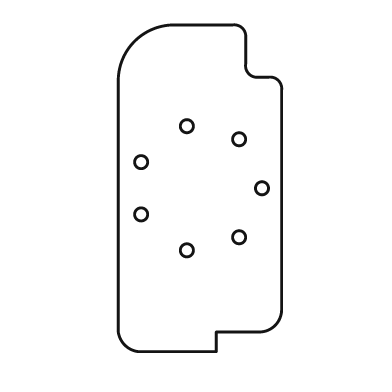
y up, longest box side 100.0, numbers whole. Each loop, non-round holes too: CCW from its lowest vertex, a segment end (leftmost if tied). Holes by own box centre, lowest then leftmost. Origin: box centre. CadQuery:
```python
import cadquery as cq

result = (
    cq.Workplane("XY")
    .moveTo(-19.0, -50.0)
    .lineTo(5.0, -50.0)
    .lineTo(5.0, -44.0)
    .lineTo(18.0, -44.0)
    .threePointArc((23.0, -42.0), (25.0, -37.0))
    .lineTo(25.0, 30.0)
    .threePointArc((24.0, 33.0), (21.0, 34.0))
    .lineTo(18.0, 34.0)
    .threePointArc((15.0, 35.0), (14.0, 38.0))
    .lineTo(14.0, 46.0)
    .threePointArc((13.0, 49.0), (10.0, 50.0))
    .lineTo(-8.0, 50.0)
    .threePointArc((-20.0, 45.0), (-25.0, 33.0))
    .lineTo(-25.0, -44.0)
    .threePointArc((-23.0, -48.0), (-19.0, -50.0))
    .close()
    .moveTo(-4.0, -19.0)
    .circle(2.0)
    .moveTo(12.0, -15.0)
    .circle(2.0)
    .moveTo(-18.0, -8.0)
    .circle(2.0)
    .moveTo(19.0, 0.0)
    .circle(2.0)
    .moveTo(-18.0, 8.0)
    .circle(2.0)
    .moveTo(12.0, 15.0)
    .circle(2.0)
    .moveTo(-4.0, 19.0)
    .circle(2.0)
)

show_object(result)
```